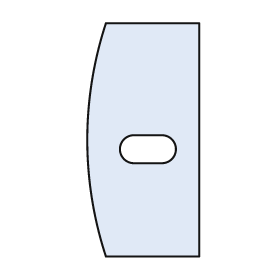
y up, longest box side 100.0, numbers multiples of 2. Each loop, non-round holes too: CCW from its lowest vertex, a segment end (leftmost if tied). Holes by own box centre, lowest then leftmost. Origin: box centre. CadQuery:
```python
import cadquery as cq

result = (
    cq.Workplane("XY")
    .moveTo(-16.0, -50.0)
    .lineTo(24.0, -50.0)
    .lineTo(24.0, 50.0)
    .lineTo(-16.0, 50.0)
    .threePointArc((-24.0, 0.0), (-16.0, -50.0))
    .close()
    .moveTo(-4.0, -10.0)
    .lineTo(8.0, -10.0)
    .threePointArc((14.0, -4.0), (8.0, 2.0))
    .lineTo(-4.0, 2.0)
    .threePointArc((-10.0, -4.0), (-4.0, -10.0))
    .close()
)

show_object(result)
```